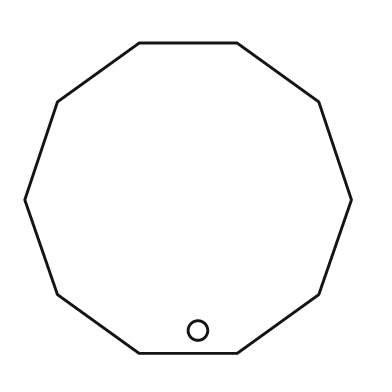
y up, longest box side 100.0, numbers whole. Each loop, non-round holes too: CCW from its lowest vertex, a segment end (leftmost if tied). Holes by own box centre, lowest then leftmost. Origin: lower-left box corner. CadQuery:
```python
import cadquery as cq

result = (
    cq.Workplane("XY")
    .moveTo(35.0, 0.0)
    .lineTo(65.0, 0.0)
    .lineTo(90.0, 18.0)
    .lineTo(100.0, 47.0)
    .lineTo(90.0, 77.0)
    .lineTo(65.0, 95.0)
    .lineTo(35.0, 95.0)
    .lineTo(10.0, 77.0)
    .lineTo(0.0, 47.0)
    .lineTo(10.0, 18.0)
    .close()
    .moveTo(53.0, 7.0)
    .circle(3.0)
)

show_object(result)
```